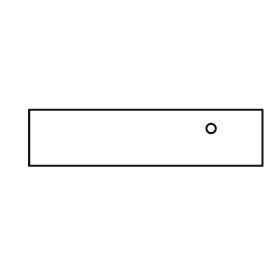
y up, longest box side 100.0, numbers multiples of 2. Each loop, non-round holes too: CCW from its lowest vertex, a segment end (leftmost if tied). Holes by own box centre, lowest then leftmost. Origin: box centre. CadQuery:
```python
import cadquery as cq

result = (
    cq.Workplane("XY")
    .moveTo(-50.0, -12.0)
    .lineTo(50.0, -12.0)
    .lineTo(50.0, 12.0)
    .lineTo(-50.0, 12.0)
    .close()
    .moveTo(28.0, 4.0)
    .circle(2.0)
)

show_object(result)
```